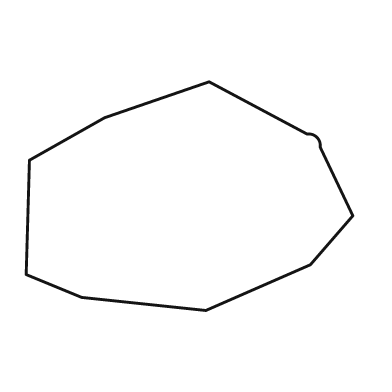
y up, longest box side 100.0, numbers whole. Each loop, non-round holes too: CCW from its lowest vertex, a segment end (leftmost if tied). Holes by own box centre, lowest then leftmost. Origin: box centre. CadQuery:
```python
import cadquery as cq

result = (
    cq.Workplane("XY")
    .moveTo(5.0, -35.0)
    .lineTo(37.0, -21.0)
    .lineTo(50.0, -6.0)
    .lineTo(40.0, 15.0)
    .threePointArc((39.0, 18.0), (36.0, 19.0))
    .lineTo(6.0, 35.0)
    .lineTo(-26.0, 24.0)
    .lineTo(-49.0, 11.0)
    .lineTo(-50.0, -24.0)
    .lineTo(-33.0, -31.0)
    .close()
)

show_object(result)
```